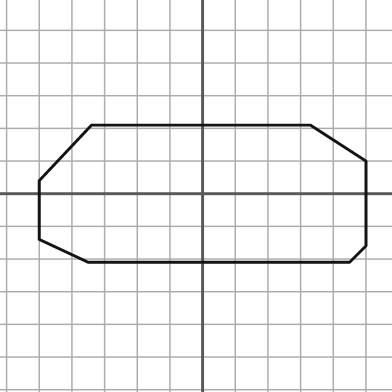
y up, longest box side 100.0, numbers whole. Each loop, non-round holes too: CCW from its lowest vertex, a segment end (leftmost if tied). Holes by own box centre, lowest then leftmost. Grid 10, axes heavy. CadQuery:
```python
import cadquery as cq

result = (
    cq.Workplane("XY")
    .moveTo(-35.0, -21.0)
    .lineTo(45.0, -21.0)
    .lineTo(50.0, -16.0)
    .lineTo(50.0, 10.0)
    .lineTo(33.0, 21.0)
    .lineTo(-34.0, 21.0)
    .lineTo(-50.0, 4.0)
    .lineTo(-50.0, -14.0)
    .close()
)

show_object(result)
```